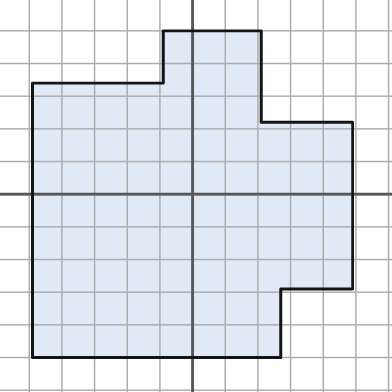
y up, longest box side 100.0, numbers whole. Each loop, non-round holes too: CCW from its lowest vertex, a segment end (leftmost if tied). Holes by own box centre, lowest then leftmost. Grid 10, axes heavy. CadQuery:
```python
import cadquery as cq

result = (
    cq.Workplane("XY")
    .moveTo(-49.0, -50.0)
    .lineTo(27.0, -50.0)
    .lineTo(27.0, -29.0)
    .lineTo(49.0, -29.0)
    .lineTo(49.0, 22.0)
    .lineTo(21.0, 22.0)
    .lineTo(21.0, 50.0)
    .lineTo(-9.0, 50.0)
    .lineTo(-9.0, 34.0)
    .lineTo(-49.0, 34.0)
    .close()
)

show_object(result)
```